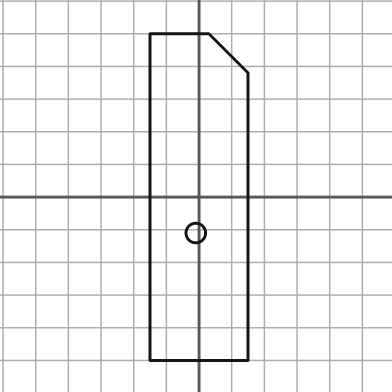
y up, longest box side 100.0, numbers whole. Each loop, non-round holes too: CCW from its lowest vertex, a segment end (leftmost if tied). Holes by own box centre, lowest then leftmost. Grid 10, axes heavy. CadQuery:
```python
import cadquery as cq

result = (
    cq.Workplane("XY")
    .moveTo(-15.0, -50.0)
    .lineTo(15.0, -50.0)
    .lineTo(15.0, 38.0)
    .lineTo(3.0, 50.0)
    .lineTo(-15.0, 50.0)
    .close()
    .moveTo(-1.0, -11.0)
    .circle(3.0)
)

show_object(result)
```